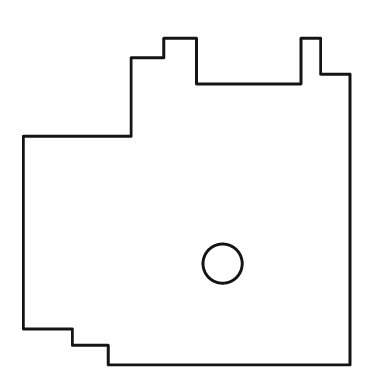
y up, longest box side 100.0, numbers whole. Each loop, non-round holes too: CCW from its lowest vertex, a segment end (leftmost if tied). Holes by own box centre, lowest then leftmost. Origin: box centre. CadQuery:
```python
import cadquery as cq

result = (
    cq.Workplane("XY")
    .moveTo(-24.0, -50.0)
    .lineTo(50.0, -50.0)
    .lineTo(50.0, 39.0)
    .lineTo(41.0, 39.0)
    .lineTo(41.0, 50.0)
    .lineTo(35.0, 50.0)
    .lineTo(35.0, 36.0)
    .lineTo(3.0, 36.0)
    .lineTo(3.0, 50.0)
    .lineTo(-7.0, 50.0)
    .lineTo(-7.0, 44.0)
    .lineTo(-17.0, 44.0)
    .lineTo(-17.0, 20.0)
    .lineTo(-50.0, 20.0)
    .lineTo(-50.0, -39.0)
    .lineTo(-35.0, -39.0)
    .lineTo(-35.0, -44.0)
    .lineTo(-24.0, -44.0)
    .close()
    .moveTo(11.0, -19.0)
    .circle(6.0)
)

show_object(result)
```